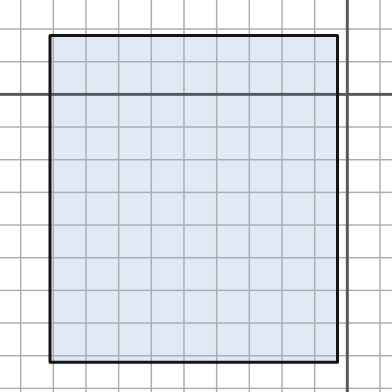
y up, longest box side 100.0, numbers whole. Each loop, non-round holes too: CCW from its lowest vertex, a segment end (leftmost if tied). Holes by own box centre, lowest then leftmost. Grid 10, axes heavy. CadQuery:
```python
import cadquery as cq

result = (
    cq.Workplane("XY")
    .moveTo(-91.0, -82.0)
    .lineTo(-3.0, -82.0)
    .lineTo(-3.0, 18.0)
    .lineTo(-91.0, 18.0)
    .close()
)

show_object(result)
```